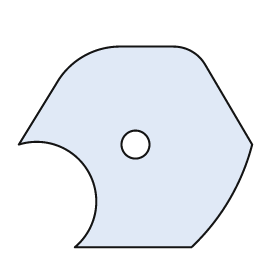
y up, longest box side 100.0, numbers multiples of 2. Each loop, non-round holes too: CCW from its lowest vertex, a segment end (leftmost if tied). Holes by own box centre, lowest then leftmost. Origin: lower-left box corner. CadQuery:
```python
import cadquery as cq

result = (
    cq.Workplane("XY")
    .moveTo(24.0, 0.0)
    .lineTo(74.0, 0.0)
    .threePointArc((90.0, 20.0), (100.0, 44.0))
    .lineTo(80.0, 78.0)
    .threePointArc((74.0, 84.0), (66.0, 86.0))
    .lineTo(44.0, 86.0)
    .threePointArc((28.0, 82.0), (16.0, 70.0))
    .lineTo(0.0, 44.0)
    .threePointArc((30.0, 32.0), (24.0, 0.0))
    .close()
    .moveTo(50.0, 44.0)
    .circle(6.0)
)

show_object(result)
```